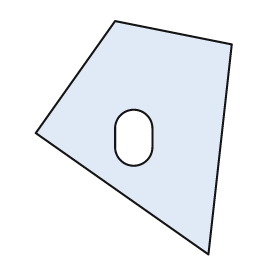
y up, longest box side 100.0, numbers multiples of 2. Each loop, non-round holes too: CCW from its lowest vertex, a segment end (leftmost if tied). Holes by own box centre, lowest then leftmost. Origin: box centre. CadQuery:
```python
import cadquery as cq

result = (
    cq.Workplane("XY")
    .moveTo(32.0, -50.0)
    .lineTo(42.0, 40.0)
    .lineTo(-8.0, 50.0)
    .lineTo(-42.0, 2.0)
    .close()
    .moveTo(-8.0, -4.0)
    .threePointArc((0.0, -12.0), (8.0, -4.0))
    .lineTo(8.0, 4.0)
    .threePointArc((0.0, 12.0), (-8.0, 4.0))
    .close()
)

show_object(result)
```